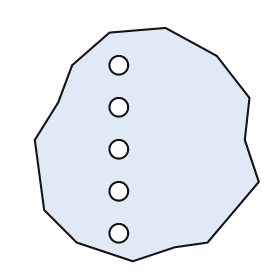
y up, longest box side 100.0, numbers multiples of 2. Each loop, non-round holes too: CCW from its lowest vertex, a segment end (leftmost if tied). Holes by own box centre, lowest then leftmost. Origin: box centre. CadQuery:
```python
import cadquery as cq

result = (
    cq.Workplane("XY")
    .moveTo(-6.0, -50.0)
    .lineTo(12.0, -44.0)
    .lineTo(26.0, -42.0)
    .lineTo(48.0, -16.0)
    .lineTo(42.0, 2.0)
    .lineTo(44.0, 20.0)
    .lineTo(30.0, 38.0)
    .lineTo(8.0, 50.0)
    .lineTo(-16.0, 48.0)
    .lineTo(-32.0, 34.0)
    .lineTo(-38.0, 18.0)
    .lineTo(-48.0, 2.0)
    .lineTo(-44.0, -28.0)
    .lineTo(-30.0, -42.0)
    .close()
    .moveTo(-12.0, -38.0)
    .circle(4.0)
    .moveTo(-12.0, -20.0)
    .circle(4.0)
    .moveTo(-12.0, -2.0)
    .circle(4.0)
    .moveTo(-12.0, 16.0)
    .circle(4.0)
    .moveTo(-12.0, 34.0)
    .circle(4.0)
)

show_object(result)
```